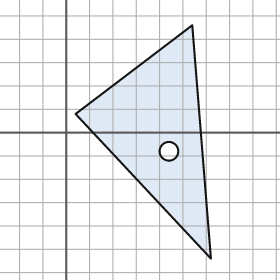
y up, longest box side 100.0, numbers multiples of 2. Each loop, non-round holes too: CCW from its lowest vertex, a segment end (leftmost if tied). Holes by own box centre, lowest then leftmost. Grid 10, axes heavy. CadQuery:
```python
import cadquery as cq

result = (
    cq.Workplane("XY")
    .moveTo(62.0, -54.0)
    .lineTo(54.0, 46.0)
    .lineTo(4.0, 8.0)
    .close()
    .moveTo(44.0, -8.0)
    .circle(4.0)
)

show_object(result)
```